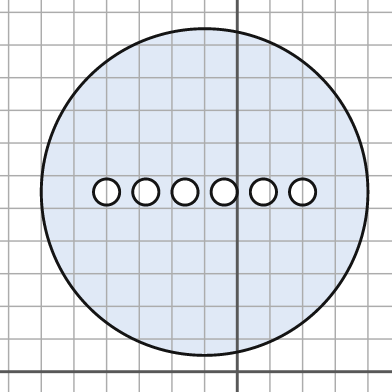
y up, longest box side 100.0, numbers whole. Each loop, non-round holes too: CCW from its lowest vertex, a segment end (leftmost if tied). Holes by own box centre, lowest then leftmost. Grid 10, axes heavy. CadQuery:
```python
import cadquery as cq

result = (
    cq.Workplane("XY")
    .moveTo(-10.0, 55.0)
    .circle(50.0)
    .moveTo(-40.0, 55.0)
    .circle(4.0)
    .moveTo(-28.0, 55.0)
    .circle(4.0)
    .moveTo(-16.0, 55.0)
    .circle(4.0)
    .moveTo(-4.0, 55.0)
    .circle(4.0)
    .moveTo(8.0, 55.0)
    .circle(4.0)
    .moveTo(20.0, 55.0)
    .circle(4.0)
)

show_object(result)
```